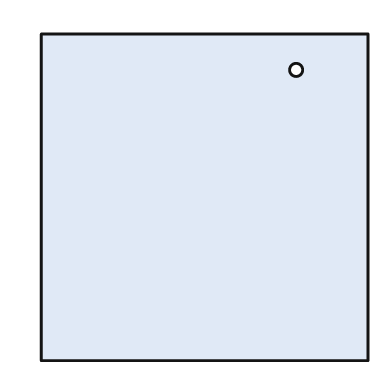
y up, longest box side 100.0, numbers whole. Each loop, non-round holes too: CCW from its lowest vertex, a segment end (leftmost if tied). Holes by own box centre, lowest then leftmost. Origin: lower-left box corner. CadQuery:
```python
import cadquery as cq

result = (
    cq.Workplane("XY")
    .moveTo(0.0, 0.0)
    .lineTo(100.0, 0.0)
    .lineTo(100.0, 100.0)
    .lineTo(0.0, 100.0)
    .close()
    .moveTo(78.0, 89.0)
    .circle(2.0)
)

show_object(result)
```